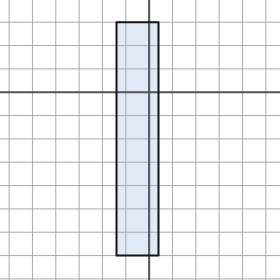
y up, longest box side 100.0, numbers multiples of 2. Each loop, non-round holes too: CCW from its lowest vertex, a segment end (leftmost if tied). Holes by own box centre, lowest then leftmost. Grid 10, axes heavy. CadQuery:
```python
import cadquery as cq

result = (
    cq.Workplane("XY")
    .moveTo(-14.0, -70.0)
    .lineTo(4.0, -70.0)
    .lineTo(4.0, 30.0)
    .lineTo(-14.0, 30.0)
    .close()
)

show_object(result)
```